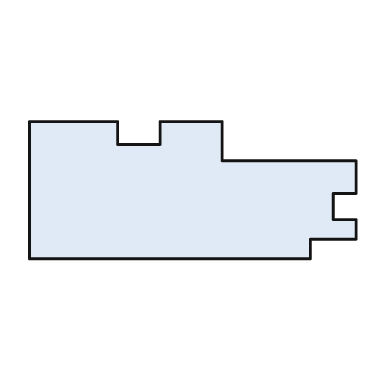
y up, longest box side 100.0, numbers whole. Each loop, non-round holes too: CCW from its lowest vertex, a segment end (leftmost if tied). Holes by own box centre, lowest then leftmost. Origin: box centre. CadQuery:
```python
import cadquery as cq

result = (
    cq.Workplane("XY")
    .moveTo(-50.0, -21.0)
    .lineTo(36.0, -21.0)
    .lineTo(36.0, -15.0)
    .lineTo(50.0, -15.0)
    .lineTo(50.0, -9.0)
    .lineTo(43.0, -9.0)
    .lineTo(43.0, -1.0)
    .lineTo(50.0, -1.0)
    .lineTo(50.0, 9.0)
    .lineTo(9.0, 9.0)
    .lineTo(9.0, 21.0)
    .lineTo(-10.0, 21.0)
    .lineTo(-10.0, 14.0)
    .lineTo(-23.0, 14.0)
    .lineTo(-23.0, 21.0)
    .lineTo(-50.0, 21.0)
    .close()
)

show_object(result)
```